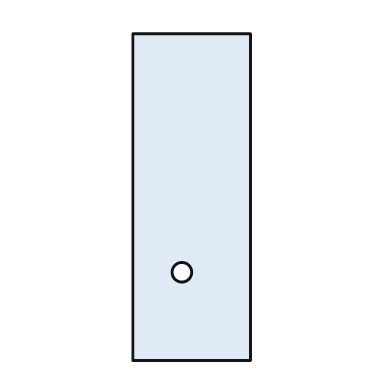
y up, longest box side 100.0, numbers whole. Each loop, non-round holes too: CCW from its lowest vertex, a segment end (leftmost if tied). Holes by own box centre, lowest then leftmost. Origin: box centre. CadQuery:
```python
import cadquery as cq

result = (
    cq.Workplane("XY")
    .moveTo(-18.0, -50.0)
    .lineTo(18.0, -50.0)
    .lineTo(18.0, 50.0)
    .lineTo(-18.0, 50.0)
    .close()
    .moveTo(-3.0, -23.0)
    .circle(3.0)
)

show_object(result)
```